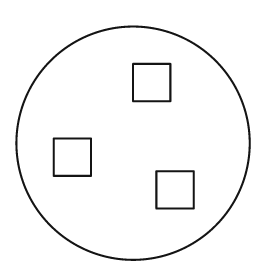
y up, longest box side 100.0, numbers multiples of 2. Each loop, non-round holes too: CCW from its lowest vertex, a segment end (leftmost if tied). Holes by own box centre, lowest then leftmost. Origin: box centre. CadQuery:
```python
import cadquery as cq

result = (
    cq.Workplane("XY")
    .moveTo(0.0, 0.0)
    .circle(50.0)
    .moveTo(10.0, -28.0)
    .lineTo(26.0, -28.0)
    .lineTo(26.0, -12.0)
    .lineTo(10.0, -12.0)
    .close()
    .moveTo(-34.0, -14.0)
    .lineTo(-18.0, -14.0)
    .lineTo(-18.0, 2.0)
    .lineTo(-34.0, 2.0)
    .close()
    .moveTo(0.0, 18.0)
    .lineTo(16.0, 18.0)
    .lineTo(16.0, 34.0)
    .lineTo(0.0, 34.0)
    .close()
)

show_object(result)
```